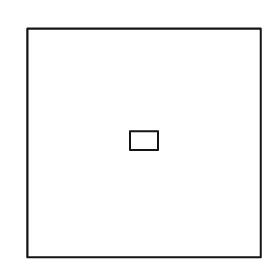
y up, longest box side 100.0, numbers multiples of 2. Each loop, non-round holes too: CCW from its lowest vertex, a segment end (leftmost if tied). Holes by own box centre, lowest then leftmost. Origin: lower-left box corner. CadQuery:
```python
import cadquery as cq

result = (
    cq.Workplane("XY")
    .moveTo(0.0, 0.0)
    .lineTo(100.0, 0.0)
    .lineTo(100.0, 98.0)
    .lineTo(0.0, 98.0)
    .close()
    .moveTo(44.0, 46.0)
    .lineTo(56.0, 46.0)
    .lineTo(56.0, 54.0)
    .lineTo(44.0, 54.0)
    .close()
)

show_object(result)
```